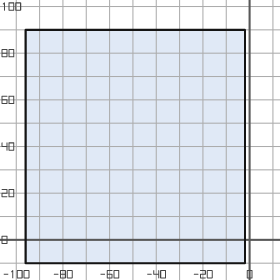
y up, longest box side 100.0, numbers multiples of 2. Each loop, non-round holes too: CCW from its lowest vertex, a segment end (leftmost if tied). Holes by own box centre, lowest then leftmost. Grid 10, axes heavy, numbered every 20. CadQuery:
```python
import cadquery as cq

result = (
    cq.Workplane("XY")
    .moveTo(-96.0, -10.0)
    .lineTo(-2.0, -10.0)
    .lineTo(-2.0, 90.0)
    .lineTo(-96.0, 90.0)
    .close()
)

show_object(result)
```